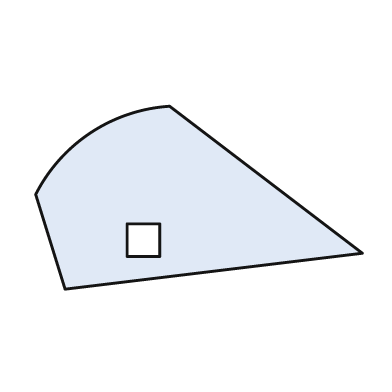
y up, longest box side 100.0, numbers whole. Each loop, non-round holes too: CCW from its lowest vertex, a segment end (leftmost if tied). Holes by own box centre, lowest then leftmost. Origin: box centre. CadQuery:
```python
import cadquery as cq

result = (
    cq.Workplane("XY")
    .moveTo(-41.0, -28.0)
    .lineTo(50.0, -17.0)
    .lineTo(-9.0, 28.0)
    .threePointArc((-33.0, 20.0), (-50.0, 1.0))
    .close()
    .moveTo(-22.0, -18.0)
    .lineTo(-12.0, -18.0)
    .lineTo(-12.0, -8.0)
    .lineTo(-22.0, -8.0)
    .close()
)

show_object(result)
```